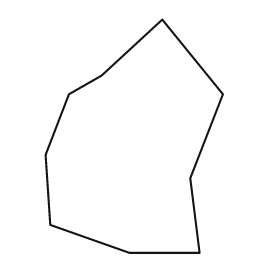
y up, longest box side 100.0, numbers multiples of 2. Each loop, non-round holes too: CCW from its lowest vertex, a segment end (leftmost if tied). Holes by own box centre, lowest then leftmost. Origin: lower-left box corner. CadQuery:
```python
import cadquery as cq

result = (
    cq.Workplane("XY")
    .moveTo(36.0, 0.0)
    .lineTo(66.0, 0.0)
    .lineTo(62.0, 32.0)
    .lineTo(76.0, 68.0)
    .lineTo(50.0, 100.0)
    .lineTo(24.0, 76.0)
    .lineTo(10.0, 68.0)
    .lineTo(0.0, 42.0)
    .lineTo(2.0, 12.0)
    .close()
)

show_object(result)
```